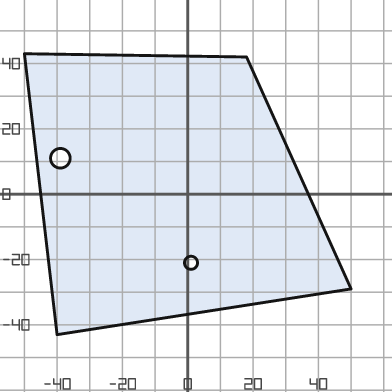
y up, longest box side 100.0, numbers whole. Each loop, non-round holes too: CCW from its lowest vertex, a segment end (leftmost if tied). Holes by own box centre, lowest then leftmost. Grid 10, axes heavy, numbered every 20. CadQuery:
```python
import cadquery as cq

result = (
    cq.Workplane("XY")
    .moveTo(-40.0, -43.0)
    .lineTo(50.0, -29.0)
    .lineTo(18.0, 42.0)
    .lineTo(-50.0, 43.0)
    .close()
    .moveTo(1.0, -21.0)
    .circle(2.0)
    .moveTo(-39.0, 11.0)
    .circle(3.0)
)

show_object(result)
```